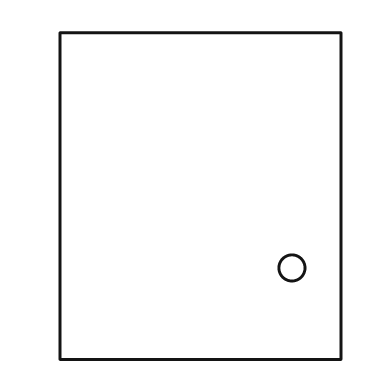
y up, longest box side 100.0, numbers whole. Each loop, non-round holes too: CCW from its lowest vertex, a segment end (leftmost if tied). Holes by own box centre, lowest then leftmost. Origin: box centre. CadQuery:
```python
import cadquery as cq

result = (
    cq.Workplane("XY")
    .moveTo(-43.0, -50.0)
    .lineTo(43.0, -50.0)
    .lineTo(43.0, 50.0)
    .lineTo(-43.0, 50.0)
    .close()
    .moveTo(28.0, -22.0)
    .circle(4.0)
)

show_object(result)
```